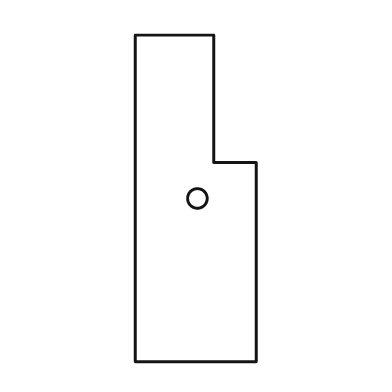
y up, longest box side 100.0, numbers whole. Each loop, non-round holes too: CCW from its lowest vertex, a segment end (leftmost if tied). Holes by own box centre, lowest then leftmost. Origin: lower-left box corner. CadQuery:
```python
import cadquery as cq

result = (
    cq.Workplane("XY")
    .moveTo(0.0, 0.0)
    .lineTo(37.0, 0.0)
    .lineTo(37.0, 61.0)
    .lineTo(24.0, 61.0)
    .lineTo(24.0, 100.0)
    .lineTo(0.0, 100.0)
    .close()
    .moveTo(19.0, 50.0)
    .circle(3.0)
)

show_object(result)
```